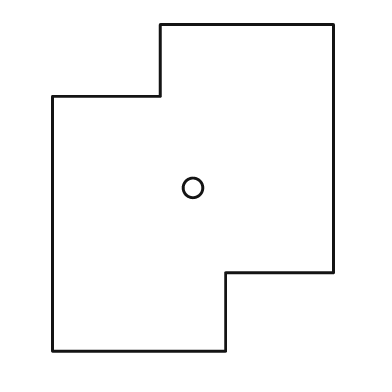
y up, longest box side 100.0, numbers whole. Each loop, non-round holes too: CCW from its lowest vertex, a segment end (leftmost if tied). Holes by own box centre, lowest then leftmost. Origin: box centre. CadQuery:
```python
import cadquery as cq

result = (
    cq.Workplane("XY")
    .moveTo(-43.0, -50.0)
    .lineTo(10.0, -50.0)
    .lineTo(10.0, -26.0)
    .lineTo(43.0, -26.0)
    .lineTo(43.0, 50.0)
    .lineTo(-10.0, 50.0)
    .lineTo(-10.0, 28.0)
    .lineTo(-43.0, 28.0)
    .close()
    .moveTo(0.0, 0.0)
    .circle(3.0)
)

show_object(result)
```